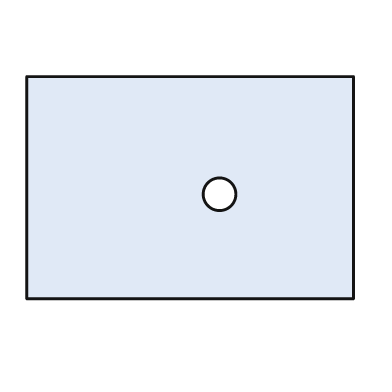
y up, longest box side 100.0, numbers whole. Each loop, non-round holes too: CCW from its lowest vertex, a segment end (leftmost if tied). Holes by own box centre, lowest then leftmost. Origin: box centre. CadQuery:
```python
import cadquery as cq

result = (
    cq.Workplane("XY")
    .moveTo(-50.0, -34.0)
    .lineTo(50.0, -34.0)
    .lineTo(50.0, 34.0)
    .lineTo(-50.0, 34.0)
    .close()
    .moveTo(9.0, -2.0)
    .circle(5.0)
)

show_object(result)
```